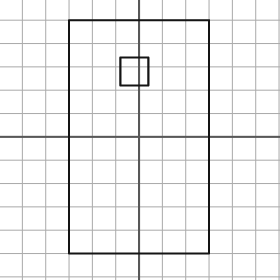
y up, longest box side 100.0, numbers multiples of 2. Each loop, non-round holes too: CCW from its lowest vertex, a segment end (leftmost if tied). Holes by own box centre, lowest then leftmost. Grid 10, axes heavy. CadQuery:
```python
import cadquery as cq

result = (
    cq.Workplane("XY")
    .moveTo(-30.0, -50.0)
    .lineTo(30.0, -50.0)
    .lineTo(30.0, 50.0)
    .lineTo(-30.0, 50.0)
    .close()
    .moveTo(-8.0, 22.0)
    .lineTo(4.0, 22.0)
    .lineTo(4.0, 34.0)
    .lineTo(-8.0, 34.0)
    .close()
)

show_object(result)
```